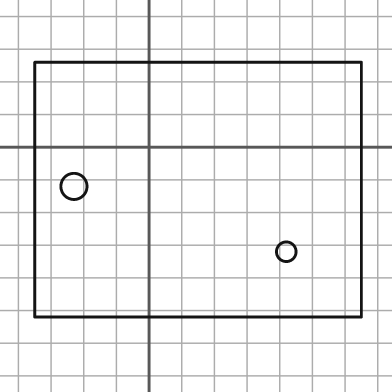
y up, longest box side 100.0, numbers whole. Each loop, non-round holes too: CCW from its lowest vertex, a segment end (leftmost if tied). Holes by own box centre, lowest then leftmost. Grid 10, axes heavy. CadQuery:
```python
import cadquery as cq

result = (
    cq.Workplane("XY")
    .moveTo(-35.0, -52.0)
    .lineTo(65.0, -52.0)
    .lineTo(65.0, 26.0)
    .lineTo(-35.0, 26.0)
    .close()
    .moveTo(42.0, -32.0)
    .circle(3.0)
    .moveTo(-23.0, -12.0)
    .circle(4.0)
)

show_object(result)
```